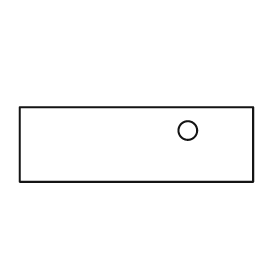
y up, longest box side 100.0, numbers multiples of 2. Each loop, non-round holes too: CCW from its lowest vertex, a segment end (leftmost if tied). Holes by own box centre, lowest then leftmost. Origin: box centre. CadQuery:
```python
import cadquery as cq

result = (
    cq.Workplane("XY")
    .moveTo(-50.0, -16.0)
    .lineTo(50.0, -16.0)
    .lineTo(50.0, 16.0)
    .lineTo(-50.0, 16.0)
    .close()
    .moveTo(22.0, 6.0)
    .circle(4.0)
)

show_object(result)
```